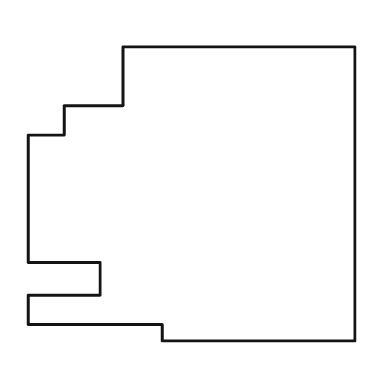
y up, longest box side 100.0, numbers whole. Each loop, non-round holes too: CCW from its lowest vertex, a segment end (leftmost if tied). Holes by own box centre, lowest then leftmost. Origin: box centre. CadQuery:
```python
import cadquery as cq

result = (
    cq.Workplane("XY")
    .moveTo(-9.0, -45.0)
    .lineTo(50.0, -45.0)
    .lineTo(50.0, 45.0)
    .lineTo(-21.0, 45.0)
    .lineTo(-21.0, 27.0)
    .lineTo(-39.0, 27.0)
    .lineTo(-39.0, 18.0)
    .lineTo(-50.0, 18.0)
    .lineTo(-50.0, -21.0)
    .lineTo(-28.0, -21.0)
    .lineTo(-28.0, -31.0)
    .lineTo(-50.0, -31.0)
    .lineTo(-50.0, -40.0)
    .lineTo(-9.0, -40.0)
    .close()
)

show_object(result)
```